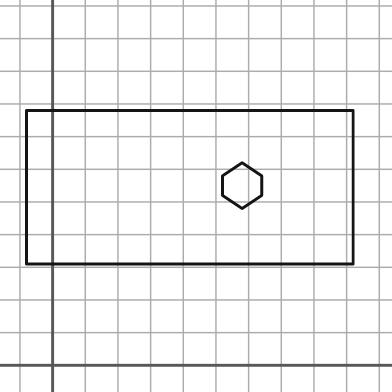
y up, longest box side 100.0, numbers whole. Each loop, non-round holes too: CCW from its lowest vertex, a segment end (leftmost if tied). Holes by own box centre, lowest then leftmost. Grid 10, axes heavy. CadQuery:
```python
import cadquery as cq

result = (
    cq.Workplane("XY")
    .moveTo(-8.0, 31.0)
    .lineTo(92.0, 31.0)
    .lineTo(92.0, 78.0)
    .lineTo(-8.0, 78.0)
    .close()
    .moveTo(58.0, 48.0)
    .lineTo(64.0, 52.0)
    .lineTo(64.0, 58.0)
    .lineTo(58.0, 62.0)
    .lineTo(52.0, 58.0)
    .lineTo(52.0, 52.0)
    .close()
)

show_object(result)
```